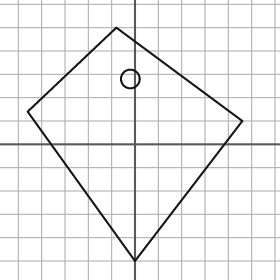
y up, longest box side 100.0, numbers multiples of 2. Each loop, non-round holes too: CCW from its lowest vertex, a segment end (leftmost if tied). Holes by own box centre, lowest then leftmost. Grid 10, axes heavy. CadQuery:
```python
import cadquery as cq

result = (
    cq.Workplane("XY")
    .moveTo(0.0, -50.0)
    .lineTo(46.0, 10.0)
    .lineTo(-8.0, 50.0)
    .lineTo(-46.0, 14.0)
    .close()
    .moveTo(-2.0, 28.0)
    .circle(4.0)
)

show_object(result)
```